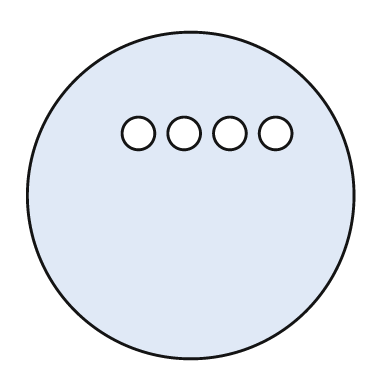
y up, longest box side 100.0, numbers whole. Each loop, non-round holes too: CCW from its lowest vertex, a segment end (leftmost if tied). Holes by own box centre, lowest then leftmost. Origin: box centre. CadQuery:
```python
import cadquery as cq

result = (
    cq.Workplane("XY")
    .moveTo(0.0, 0.0)
    .circle(50.0)
    .moveTo(-16.0, 19.0)
    .circle(5.0)
    .moveTo(-2.0, 19.0)
    .circle(5.0)
    .moveTo(12.0, 19.0)
    .circle(5.0)
    .moveTo(26.0, 19.0)
    .circle(5.0)
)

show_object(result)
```